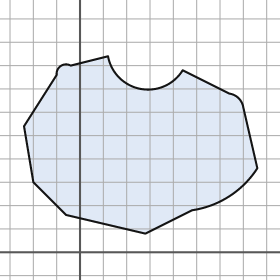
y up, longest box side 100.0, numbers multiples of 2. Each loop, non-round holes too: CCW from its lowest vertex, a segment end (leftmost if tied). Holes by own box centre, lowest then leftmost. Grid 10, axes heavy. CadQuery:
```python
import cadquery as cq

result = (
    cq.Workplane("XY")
    .moveTo(28.0, 8.0)
    .lineTo(48.0, 18.0)
    .threePointArc((64.0, 24.0), (76.0, 36.0))
    .lineTo(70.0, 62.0)
    .threePointArc((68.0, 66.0), (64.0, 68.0))
    .lineTo(44.0, 78.0)
    .threePointArc((26.0, 70.0), (12.0, 84.0))
    .lineTo(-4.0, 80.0)
    .threePointArc((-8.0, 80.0), (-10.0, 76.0))
    .lineTo(-24.0, 54.0)
    .lineTo(-20.0, 30.0)
    .lineTo(-6.0, 16.0)
    .close()
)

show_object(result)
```